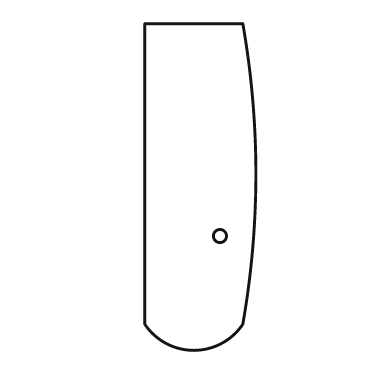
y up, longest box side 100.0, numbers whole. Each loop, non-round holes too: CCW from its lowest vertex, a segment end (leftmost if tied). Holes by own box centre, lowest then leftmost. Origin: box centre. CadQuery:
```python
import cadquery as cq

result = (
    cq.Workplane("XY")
    .moveTo(-17.0, -42.0)
    .threePointArc((-2.0, -50.0), (13.0, -42.0))
    .threePointArc((17.0, 4.0), (13.0, 50.0))
    .lineTo(-17.0, 50.0)
    .close()
    .moveTo(6.0, -15.0)
    .circle(2.0)
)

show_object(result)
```